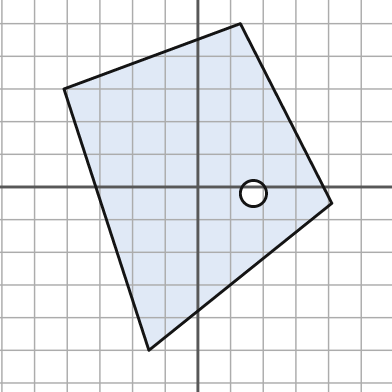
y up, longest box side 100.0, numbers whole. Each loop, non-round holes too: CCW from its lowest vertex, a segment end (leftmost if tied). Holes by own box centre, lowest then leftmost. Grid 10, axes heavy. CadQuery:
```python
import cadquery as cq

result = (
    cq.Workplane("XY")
    .moveTo(-15.0, -50.0)
    .lineTo(41.0, -5.0)
    .lineTo(13.0, 50.0)
    .lineTo(-41.0, 30.0)
    .close()
    .moveTo(17.0, -2.0)
    .circle(4.0)
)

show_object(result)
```